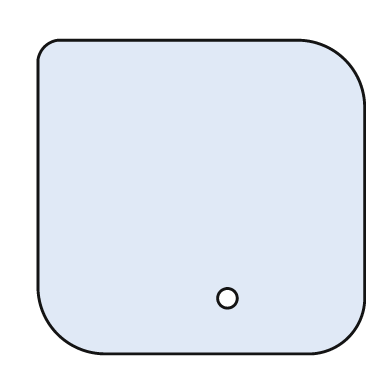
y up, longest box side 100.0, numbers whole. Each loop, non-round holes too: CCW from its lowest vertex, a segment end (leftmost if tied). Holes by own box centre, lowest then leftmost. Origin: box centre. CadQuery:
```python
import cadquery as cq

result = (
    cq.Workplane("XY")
    .moveTo(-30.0, -48.0)
    .lineTo(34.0, -48.0)
    .threePointArc((45.0, -43.0), (50.0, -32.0))
    .lineTo(50.0, 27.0)
    .threePointArc((44.0, 42.0), (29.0, 48.0))
    .lineTo(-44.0, 48.0)
    .threePointArc((-48.0, 46.0), (-50.0, 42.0))
    .lineTo(-50.0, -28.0)
    .threePointArc((-44.0, -42.0), (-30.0, -48.0))
    .close()
    .moveTo(8.0, -31.0)
    .circle(3.0)
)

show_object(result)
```